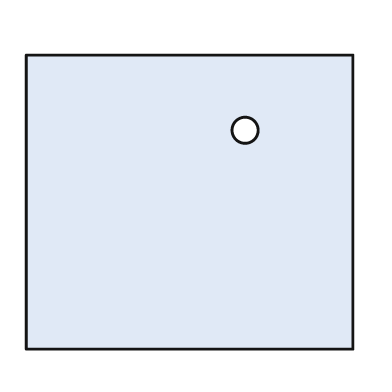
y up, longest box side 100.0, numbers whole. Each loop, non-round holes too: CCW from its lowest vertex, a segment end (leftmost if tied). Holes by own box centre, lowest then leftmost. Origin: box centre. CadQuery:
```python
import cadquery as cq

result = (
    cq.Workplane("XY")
    .moveTo(-50.0, -45.0)
    .lineTo(50.0, -45.0)
    .lineTo(50.0, 45.0)
    .lineTo(-50.0, 45.0)
    .close()
    .moveTo(17.0, 22.0)
    .circle(4.0)
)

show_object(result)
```